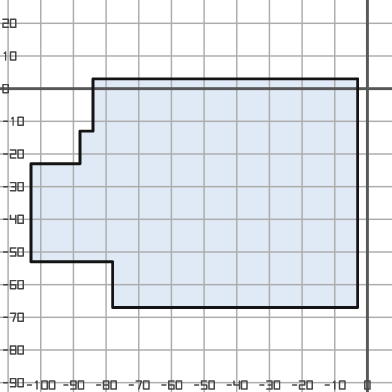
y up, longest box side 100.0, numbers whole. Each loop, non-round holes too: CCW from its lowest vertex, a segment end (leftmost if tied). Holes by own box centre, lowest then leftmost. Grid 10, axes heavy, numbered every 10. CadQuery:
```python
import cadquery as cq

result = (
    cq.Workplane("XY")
    .moveTo(-78.0, -67.0)
    .lineTo(-3.0, -67.0)
    .lineTo(-3.0, 3.0)
    .lineTo(-84.0, 3.0)
    .lineTo(-84.0, -13.0)
    .lineTo(-88.0, -13.0)
    .lineTo(-88.0, -23.0)
    .lineTo(-103.0, -23.0)
    .lineTo(-103.0, -53.0)
    .lineTo(-78.0, -53.0)
    .close()
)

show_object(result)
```